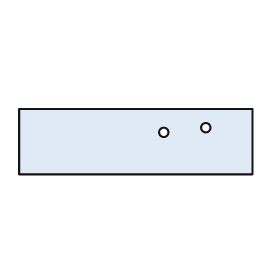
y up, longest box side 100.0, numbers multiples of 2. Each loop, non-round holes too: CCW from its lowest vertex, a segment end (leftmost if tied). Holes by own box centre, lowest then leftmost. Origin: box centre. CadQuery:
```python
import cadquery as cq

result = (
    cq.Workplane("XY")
    .moveTo(-50.0, -14.0)
    .lineTo(50.0, -14.0)
    .lineTo(50.0, 14.0)
    .lineTo(-50.0, 14.0)
    .close()
    .moveTo(12.0, 4.0)
    .circle(2.0)
    .moveTo(30.0, 6.0)
    .circle(2.0)
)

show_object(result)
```